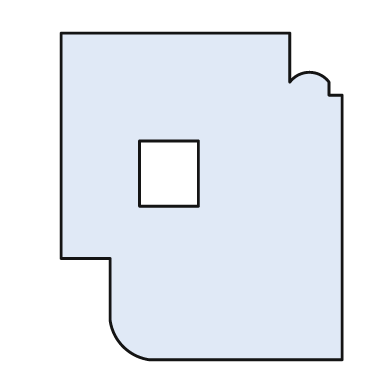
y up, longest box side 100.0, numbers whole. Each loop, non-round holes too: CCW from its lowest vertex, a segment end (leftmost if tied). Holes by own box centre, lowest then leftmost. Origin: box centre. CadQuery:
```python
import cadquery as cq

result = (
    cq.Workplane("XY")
    .moveTo(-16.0, -50.0)
    .lineTo(43.0, -50.0)
    .lineTo(43.0, 31.0)
    .lineTo(39.0, 31.0)
    .lineTo(39.0, 35.0)
    .threePointArc((33.0, 38.0), (27.0, 35.0))
    .lineTo(27.0, 50.0)
    .lineTo(-43.0, 50.0)
    .lineTo(-43.0, -19.0)
    .lineTo(-28.0, -19.0)
    .lineTo(-28.0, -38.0)
    .threePointArc((-24.0, -46.0), (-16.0, -50.0))
    .close()
    .moveTo(-19.0, -3.0)
    .lineTo(-1.0, -3.0)
    .lineTo(-1.0, 17.0)
    .lineTo(-19.0, 17.0)
    .close()
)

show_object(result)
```